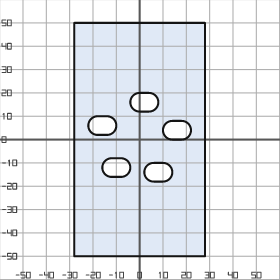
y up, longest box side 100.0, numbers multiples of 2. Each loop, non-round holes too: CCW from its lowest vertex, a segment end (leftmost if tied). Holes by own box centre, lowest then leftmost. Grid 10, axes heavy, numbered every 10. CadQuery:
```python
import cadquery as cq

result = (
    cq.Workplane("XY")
    .moveTo(-28.0, -50.0)
    .lineTo(28.0, -50.0)
    .lineTo(28.0, 50.0)
    .lineTo(-28.0, 50.0)
    .close()
    .moveTo(6.0, -18.0)
    .lineTo(10.0, -18.0)
    .threePointArc((14.0, -14.0), (10.0, -10.0))
    .lineTo(6.0, -10.0)
    .threePointArc((2.0, -14.0), (6.0, -18.0))
    .close()
    .moveTo(-12.0, -16.0)
    .lineTo(-8.0, -16.0)
    .threePointArc((-4.0, -12.0), (-8.0, -8.0))
    .lineTo(-12.0, -8.0)
    .threePointArc((-16.0, -12.0), (-12.0, -16.0))
    .close()
    .moveTo(14.0, 0.0)
    .lineTo(18.0, 0.0)
    .threePointArc((22.0, 4.0), (18.0, 8.0))
    .lineTo(14.0, 8.0)
    .threePointArc((10.0, 4.0), (14.0, 0.0))
    .close()
    .moveTo(-18.0, 2.0)
    .lineTo(-14.0, 2.0)
    .threePointArc((-10.0, 6.0), (-14.0, 10.0))
    .lineTo(-18.0, 10.0)
    .threePointArc((-22.0, 6.0), (-18.0, 2.0))
    .close()
    .moveTo(0.0, 12.0)
    .lineTo(4.0, 12.0)
    .threePointArc((8.0, 16.0), (4.0, 20.0))
    .lineTo(0.0, 20.0)
    .threePointArc((-4.0, 16.0), (0.0, 12.0))
    .close()
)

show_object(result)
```